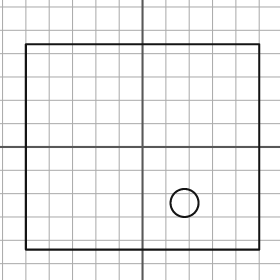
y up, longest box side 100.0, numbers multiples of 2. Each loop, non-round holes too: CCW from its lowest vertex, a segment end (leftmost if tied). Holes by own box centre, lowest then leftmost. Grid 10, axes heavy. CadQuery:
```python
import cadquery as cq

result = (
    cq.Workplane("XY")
    .moveTo(-50.0, -44.0)
    .lineTo(50.0, -44.0)
    .lineTo(50.0, 44.0)
    .lineTo(-50.0, 44.0)
    .close()
    .moveTo(18.0, -24.0)
    .circle(6.0)
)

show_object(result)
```